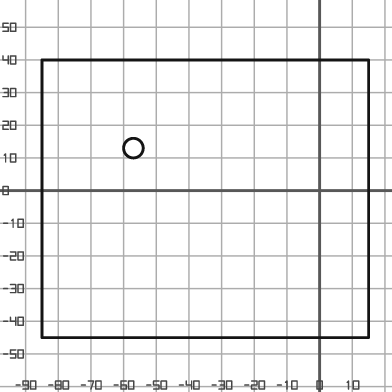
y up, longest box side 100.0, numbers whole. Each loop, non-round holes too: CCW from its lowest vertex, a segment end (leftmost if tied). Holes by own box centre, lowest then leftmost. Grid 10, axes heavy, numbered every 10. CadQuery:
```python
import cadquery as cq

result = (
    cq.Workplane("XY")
    .moveTo(-85.0, -45.0)
    .lineTo(15.0, -45.0)
    .lineTo(15.0, 40.0)
    .lineTo(-85.0, 40.0)
    .close()
    .moveTo(-57.0, 13.0)
    .circle(3.0)
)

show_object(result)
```